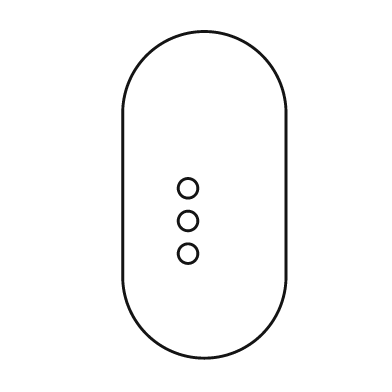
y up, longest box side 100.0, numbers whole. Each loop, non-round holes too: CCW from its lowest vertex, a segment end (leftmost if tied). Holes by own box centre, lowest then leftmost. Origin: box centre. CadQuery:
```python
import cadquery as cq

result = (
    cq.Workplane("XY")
    .moveTo(-25.0, -25.0)
    .threePointArc((0.0, -50.0), (25.0, -25.0))
    .lineTo(25.0, 25.0)
    .threePointArc((0.0, 50.0), (-25.0, 25.0))
    .close()
    .moveTo(-5.0, -18.0)
    .circle(3.0)
    .moveTo(-5.0, -8.0)
    .circle(3.0)
    .moveTo(-5.0, 2.0)
    .circle(3.0)
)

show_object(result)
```